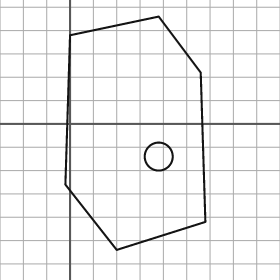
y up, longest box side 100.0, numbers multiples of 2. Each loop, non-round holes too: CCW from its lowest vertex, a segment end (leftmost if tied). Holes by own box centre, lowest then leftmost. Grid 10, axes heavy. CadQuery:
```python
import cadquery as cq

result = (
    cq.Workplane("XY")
    .moveTo(20.0, -54.0)
    .lineTo(58.0, -42.0)
    .lineTo(56.0, 22.0)
    .lineTo(38.0, 46.0)
    .lineTo(0.0, 38.0)
    .lineTo(-2.0, -26.0)
    .close()
    .moveTo(38.0, -14.0)
    .circle(6.0)
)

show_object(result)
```